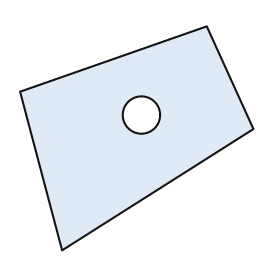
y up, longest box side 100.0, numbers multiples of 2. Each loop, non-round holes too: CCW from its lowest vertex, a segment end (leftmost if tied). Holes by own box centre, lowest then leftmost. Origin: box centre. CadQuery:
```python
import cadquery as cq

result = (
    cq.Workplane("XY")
    .moveTo(-32.0, -48.0)
    .lineTo(50.0, 4.0)
    .lineTo(30.0, 48.0)
    .lineTo(-50.0, 20.0)
    .close()
    .moveTo(2.0, 10.0)
    .circle(8.0)
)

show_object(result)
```